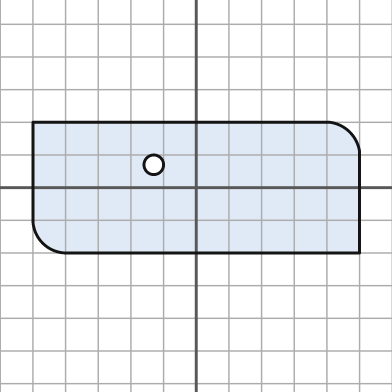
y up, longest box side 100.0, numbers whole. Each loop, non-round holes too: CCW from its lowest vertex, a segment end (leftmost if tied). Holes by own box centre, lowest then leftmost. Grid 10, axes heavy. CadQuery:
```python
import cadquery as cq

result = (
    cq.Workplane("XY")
    .moveTo(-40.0, -20.0)
    .lineTo(50.0, -20.0)
    .lineTo(50.0, 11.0)
    .threePointArc((47.0, 17.0), (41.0, 20.0))
    .lineTo(-50.0, 20.0)
    .lineTo(-50.0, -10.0)
    .threePointArc((-47.0, -17.0), (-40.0, -20.0))
    .close()
    .moveTo(-13.0, 7.0)
    .circle(3.0)
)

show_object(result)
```